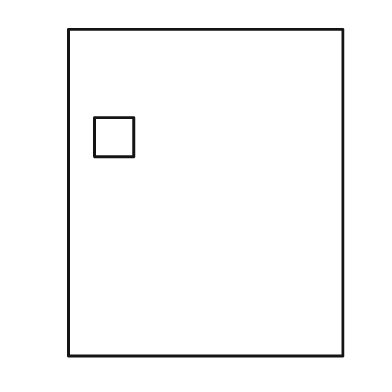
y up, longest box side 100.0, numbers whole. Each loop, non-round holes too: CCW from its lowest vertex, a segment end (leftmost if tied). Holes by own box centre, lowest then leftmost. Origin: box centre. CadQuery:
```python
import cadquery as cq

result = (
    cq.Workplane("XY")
    .moveTo(-42.0, -50.0)
    .lineTo(42.0, -50.0)
    .lineTo(42.0, 50.0)
    .lineTo(-42.0, 50.0)
    .close()
    .moveTo(-34.0, 11.0)
    .lineTo(-22.0, 11.0)
    .lineTo(-22.0, 23.0)
    .lineTo(-34.0, 23.0)
    .close()
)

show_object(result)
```